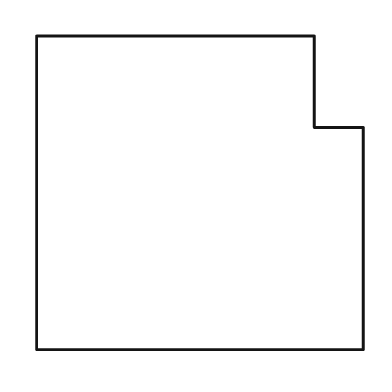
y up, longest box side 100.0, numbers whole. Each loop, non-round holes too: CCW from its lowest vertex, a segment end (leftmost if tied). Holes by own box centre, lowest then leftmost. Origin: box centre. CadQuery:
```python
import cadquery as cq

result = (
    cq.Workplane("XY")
    .moveTo(-50.0, -48.0)
    .lineTo(50.0, -48.0)
    .lineTo(50.0, 20.0)
    .lineTo(35.0, 20.0)
    .lineTo(35.0, 48.0)
    .lineTo(-50.0, 48.0)
    .close()
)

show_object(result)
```